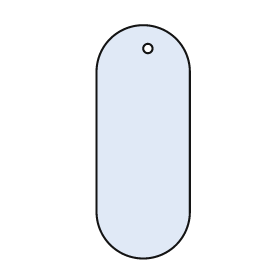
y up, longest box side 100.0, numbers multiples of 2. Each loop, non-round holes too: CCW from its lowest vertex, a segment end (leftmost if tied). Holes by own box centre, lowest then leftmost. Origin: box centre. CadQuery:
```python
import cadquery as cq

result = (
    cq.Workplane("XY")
    .moveTo(-20.0, -30.0)
    .threePointArc((0.0, -50.0), (20.0, -30.0))
    .lineTo(20.0, 30.0)
    .threePointArc((0.0, 50.0), (-20.0, 30.0))
    .close()
    .moveTo(2.0, 40.0)
    .circle(2.0)
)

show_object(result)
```